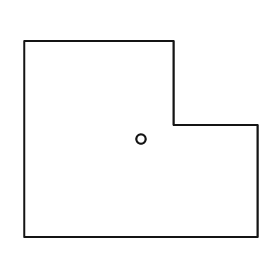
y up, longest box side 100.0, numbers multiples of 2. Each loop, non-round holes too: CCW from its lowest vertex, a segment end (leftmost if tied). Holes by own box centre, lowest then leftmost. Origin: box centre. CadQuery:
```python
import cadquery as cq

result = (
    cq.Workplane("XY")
    .moveTo(-50.0, -42.0)
    .lineTo(50.0, -42.0)
    .lineTo(50.0, 6.0)
    .lineTo(14.0, 6.0)
    .lineTo(14.0, 42.0)
    .lineTo(-50.0, 42.0)
    .close()
    .moveTo(0.0, 0.0)
    .circle(2.0)
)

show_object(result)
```